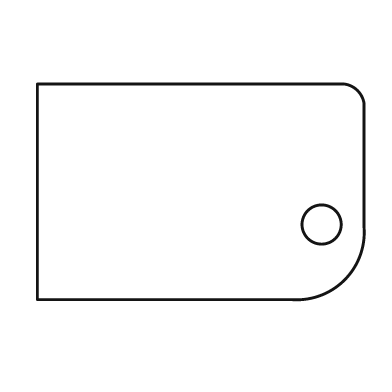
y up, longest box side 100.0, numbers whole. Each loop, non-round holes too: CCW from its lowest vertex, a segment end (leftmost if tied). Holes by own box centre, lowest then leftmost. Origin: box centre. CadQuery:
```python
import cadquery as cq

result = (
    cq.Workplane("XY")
    .moveTo(-50.0, -33.0)
    .lineTo(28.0, -33.0)
    .threePointArc((44.0, -27.0), (50.0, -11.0))
    .lineTo(50.0, 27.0)
    .threePointArc((48.0, 31.0), (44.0, 33.0))
    .lineTo(-50.0, 33.0)
    .close()
    .moveTo(37.0, -10.0)
    .circle(6.0)
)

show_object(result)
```